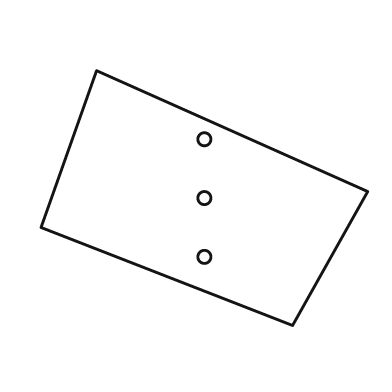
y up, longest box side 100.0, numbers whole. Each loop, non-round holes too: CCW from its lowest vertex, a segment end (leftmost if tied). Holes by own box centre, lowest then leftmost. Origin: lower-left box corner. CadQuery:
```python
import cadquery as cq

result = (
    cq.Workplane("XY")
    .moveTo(77.0, 0.0)
    .lineTo(100.0, 41.0)
    .lineTo(17.0, 78.0)
    .lineTo(0.0, 30.0)
    .close()
    .moveTo(50.0, 21.0)
    .circle(2.0)
    .moveTo(50.0, 39.0)
    .circle(2.0)
    .moveTo(50.0, 57.0)
    .circle(2.0)
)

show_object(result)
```